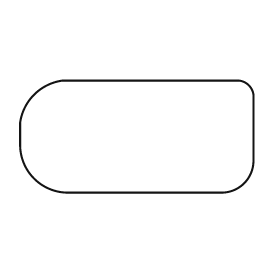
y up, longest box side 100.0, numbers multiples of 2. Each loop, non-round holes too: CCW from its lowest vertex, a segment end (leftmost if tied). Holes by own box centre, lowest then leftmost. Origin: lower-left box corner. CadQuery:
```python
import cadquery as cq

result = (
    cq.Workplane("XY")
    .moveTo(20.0, 0.0)
    .lineTo(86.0, 0.0)
    .threePointArc((96.0, 4.0), (100.0, 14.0))
    .lineTo(100.0, 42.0)
    .threePointArc((98.0, 46.0), (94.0, 48.0))
    .lineTo(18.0, 48.0)
    .threePointArc((6.0, 42.0), (0.0, 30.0))
    .lineTo(0.0, 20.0)
    .threePointArc((6.0, 6.0), (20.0, 0.0))
    .close()
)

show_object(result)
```